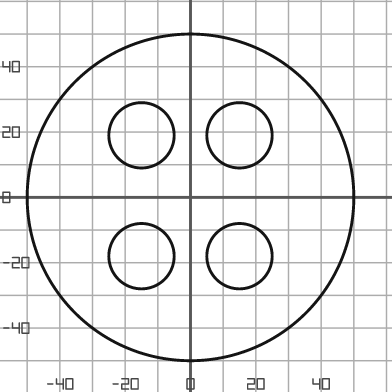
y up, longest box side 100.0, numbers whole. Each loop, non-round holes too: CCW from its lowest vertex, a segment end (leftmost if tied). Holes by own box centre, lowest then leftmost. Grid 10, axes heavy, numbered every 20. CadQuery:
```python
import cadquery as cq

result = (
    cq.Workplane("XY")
    .moveTo(0.0, 0.0)
    .circle(50.0)
    .moveTo(-15.0, -18.0)
    .circle(10.0)
    .moveTo(15.0, -18.0)
    .circle(10.0)
    .moveTo(-15.0, 19.0)
    .circle(10.0)
    .moveTo(15.0, 19.0)
    .circle(10.0)
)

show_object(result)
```